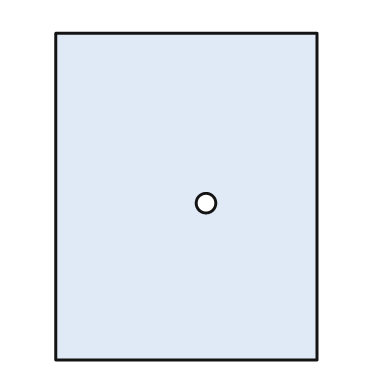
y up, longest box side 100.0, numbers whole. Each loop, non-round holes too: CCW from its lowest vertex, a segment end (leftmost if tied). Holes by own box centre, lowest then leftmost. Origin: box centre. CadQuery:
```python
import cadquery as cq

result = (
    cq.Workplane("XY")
    .moveTo(-40.0, -50.0)
    .lineTo(40.0, -50.0)
    .lineTo(40.0, 50.0)
    .lineTo(-40.0, 50.0)
    .close()
    .moveTo(6.0, -2.0)
    .circle(3.0)
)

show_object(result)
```